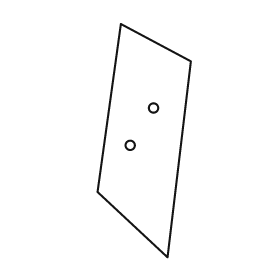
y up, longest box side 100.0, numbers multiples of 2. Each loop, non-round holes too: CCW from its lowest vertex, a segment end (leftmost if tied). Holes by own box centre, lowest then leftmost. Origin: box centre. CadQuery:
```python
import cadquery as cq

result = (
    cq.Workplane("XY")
    .moveTo(10.0, -50.0)
    .lineTo(20.0, 34.0)
    .lineTo(-10.0, 50.0)
    .lineTo(-20.0, -22.0)
    .close()
    .moveTo(-6.0, -2.0)
    .circle(2.0)
    .moveTo(4.0, 14.0)
    .circle(2.0)
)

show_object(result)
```